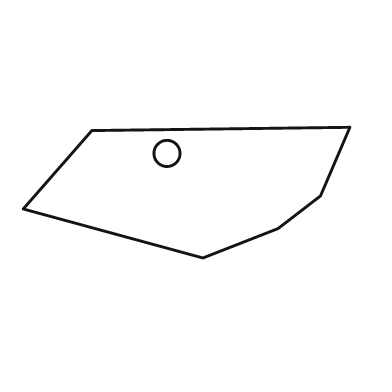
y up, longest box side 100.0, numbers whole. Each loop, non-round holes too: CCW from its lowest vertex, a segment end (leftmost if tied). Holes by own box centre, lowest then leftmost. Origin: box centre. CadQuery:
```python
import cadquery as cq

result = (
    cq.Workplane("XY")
    .moveTo(5.0, -20.0)
    .lineTo(28.0, -11.0)
    .lineTo(41.0, -1.0)
    .lineTo(50.0, 20.0)
    .lineTo(-29.0, 19.0)
    .lineTo(-50.0, -5.0)
    .close()
    .moveTo(-6.0, 12.0)
    .circle(4.0)
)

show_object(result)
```